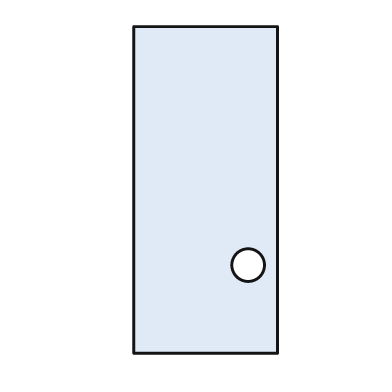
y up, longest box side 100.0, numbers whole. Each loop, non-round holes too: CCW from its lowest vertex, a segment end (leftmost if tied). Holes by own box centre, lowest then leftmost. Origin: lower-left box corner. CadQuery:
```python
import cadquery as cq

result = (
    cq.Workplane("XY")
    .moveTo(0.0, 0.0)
    .lineTo(44.0, 0.0)
    .lineTo(44.0, 100.0)
    .lineTo(0.0, 100.0)
    .close()
    .moveTo(35.0, 27.0)
    .circle(5.0)
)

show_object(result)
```